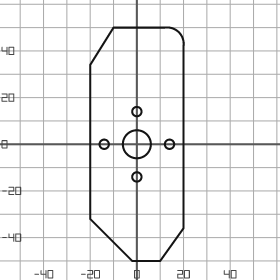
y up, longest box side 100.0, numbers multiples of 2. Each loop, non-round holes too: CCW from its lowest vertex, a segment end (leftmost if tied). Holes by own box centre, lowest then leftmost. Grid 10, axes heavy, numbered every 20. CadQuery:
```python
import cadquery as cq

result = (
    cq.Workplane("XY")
    .moveTo(-2.0, -50.0)
    .lineTo(10.0, -50.0)
    .lineTo(20.0, -36.0)
    .lineTo(20.0, 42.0)
    .threePointArc((18.0, 48.0), (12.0, 50.0))
    .lineTo(-10.0, 50.0)
    .lineTo(-20.0, 34.0)
    .lineTo(-20.0, -32.0)
    .close()
    .moveTo(0.0, -14.0)
    .circle(2.0)
    .moveTo(-14.0, 0.0)
    .circle(2.0)
    .moveTo(0.0, 0.0)
    .circle(6.0)
    .moveTo(14.0, 0.0)
    .circle(2.0)
    .moveTo(0.0, 14.0)
    .circle(2.0)
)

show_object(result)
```